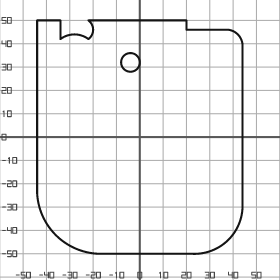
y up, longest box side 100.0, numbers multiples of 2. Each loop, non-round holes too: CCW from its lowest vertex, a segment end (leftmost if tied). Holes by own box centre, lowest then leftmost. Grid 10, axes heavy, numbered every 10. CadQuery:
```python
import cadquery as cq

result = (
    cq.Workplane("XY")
    .moveTo(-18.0, -50.0)
    .lineTo(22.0, -50.0)
    .threePointArc((38.0, -44.0), (44.0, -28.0))
    .lineTo(44.0, 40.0)
    .threePointArc((42.0, 44.0), (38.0, 46.0))
    .lineTo(20.0, 46.0)
    .lineTo(20.0, 50.0)
    .lineTo(-22.0, 50.0)
    .threePointArc((-20.0, 46.0), (-22.0, 42.0))
    .threePointArc((-28.0, 44.0), (-34.0, 42.0))
    .lineTo(-34.0, 50.0)
    .lineTo(-44.0, 50.0)
    .lineTo(-44.0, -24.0)
    .threePointArc((-36.0, -42.0), (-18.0, -50.0))
    .close()
    .moveTo(-4.0, 32.0)
    .circle(4.0)
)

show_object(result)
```